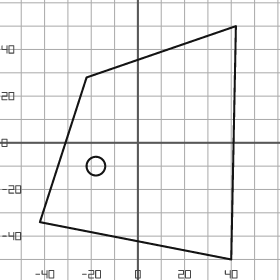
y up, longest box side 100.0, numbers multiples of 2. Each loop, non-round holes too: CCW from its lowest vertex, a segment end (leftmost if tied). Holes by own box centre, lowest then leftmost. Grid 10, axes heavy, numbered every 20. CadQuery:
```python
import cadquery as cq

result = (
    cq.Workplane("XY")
    .moveTo(40.0, -50.0)
    .lineTo(42.0, 50.0)
    .lineTo(-22.0, 28.0)
    .lineTo(-42.0, -34.0)
    .close()
    .moveTo(-18.0, -10.0)
    .circle(4.0)
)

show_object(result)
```